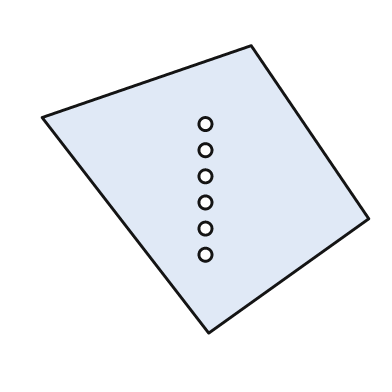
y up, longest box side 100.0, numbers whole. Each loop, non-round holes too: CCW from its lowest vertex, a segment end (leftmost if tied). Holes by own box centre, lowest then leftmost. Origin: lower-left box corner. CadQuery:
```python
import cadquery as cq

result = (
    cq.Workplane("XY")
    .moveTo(51.0, 0.0)
    .lineTo(100.0, 35.0)
    .lineTo(64.0, 88.0)
    .lineTo(0.0, 66.0)
    .close()
    .moveTo(50.0, 24.0)
    .circle(2.0)
    .moveTo(50.0, 32.0)
    .circle(2.0)
    .moveTo(50.0, 40.0)
    .circle(2.0)
    .moveTo(50.0, 48.0)
    .circle(2.0)
    .moveTo(50.0, 56.0)
    .circle(2.0)
    .moveTo(50.0, 64.0)
    .circle(2.0)
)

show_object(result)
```